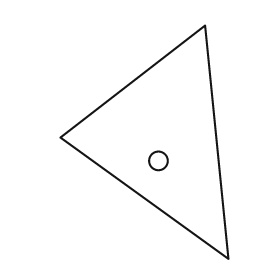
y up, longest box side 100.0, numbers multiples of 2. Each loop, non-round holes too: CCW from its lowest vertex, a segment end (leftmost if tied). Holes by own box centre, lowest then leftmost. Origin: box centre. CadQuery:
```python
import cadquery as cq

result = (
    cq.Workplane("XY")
    .moveTo(36.0, -50.0)
    .lineTo(26.0, 50.0)
    .lineTo(-36.0, 2.0)
    .close()
    .moveTo(6.0, -8.0)
    .circle(4.0)
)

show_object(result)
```